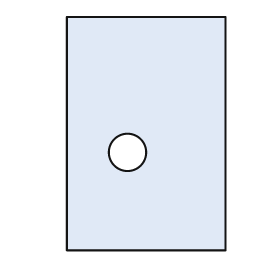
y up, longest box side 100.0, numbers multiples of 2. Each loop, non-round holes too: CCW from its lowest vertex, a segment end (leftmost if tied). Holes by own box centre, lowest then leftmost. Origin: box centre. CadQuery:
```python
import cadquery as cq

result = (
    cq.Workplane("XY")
    .moveTo(-34.0, -50.0)
    .lineTo(34.0, -50.0)
    .lineTo(34.0, 50.0)
    .lineTo(-34.0, 50.0)
    .close()
    .moveTo(-8.0, -8.0)
    .circle(8.0)
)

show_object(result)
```